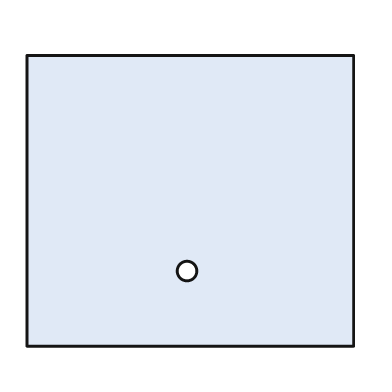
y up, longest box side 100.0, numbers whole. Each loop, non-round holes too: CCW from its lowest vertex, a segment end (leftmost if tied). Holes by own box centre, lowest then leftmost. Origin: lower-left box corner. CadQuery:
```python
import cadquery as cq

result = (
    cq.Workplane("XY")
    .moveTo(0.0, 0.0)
    .lineTo(100.0, 0.0)
    .lineTo(100.0, 89.0)
    .lineTo(0.0, 89.0)
    .close()
    .moveTo(49.0, 23.0)
    .circle(3.0)
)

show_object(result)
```